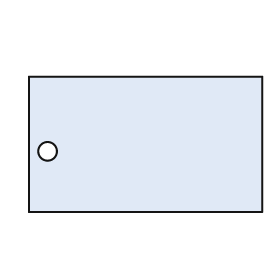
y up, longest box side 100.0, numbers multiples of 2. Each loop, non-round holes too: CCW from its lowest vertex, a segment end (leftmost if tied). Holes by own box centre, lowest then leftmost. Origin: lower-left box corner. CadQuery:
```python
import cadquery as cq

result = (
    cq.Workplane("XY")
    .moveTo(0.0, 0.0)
    .lineTo(100.0, 0.0)
    .lineTo(100.0, 58.0)
    .lineTo(0.0, 58.0)
    .close()
    .moveTo(8.0, 26.0)
    .circle(4.0)
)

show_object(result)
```